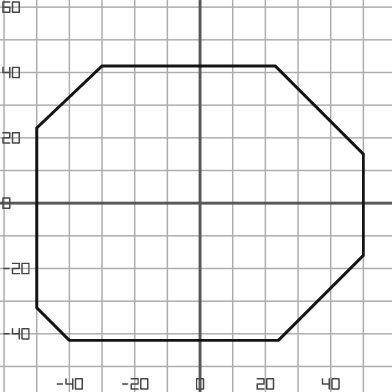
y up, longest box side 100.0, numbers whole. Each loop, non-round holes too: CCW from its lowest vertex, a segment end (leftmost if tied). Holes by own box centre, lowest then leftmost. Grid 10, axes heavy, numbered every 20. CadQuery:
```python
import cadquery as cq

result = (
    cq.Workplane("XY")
    .moveTo(-40.0, -42.0)
    .lineTo(24.0, -42.0)
    .lineTo(50.0, -16.0)
    .lineTo(50.0, 15.0)
    .lineTo(23.0, 42.0)
    .lineTo(-30.0, 42.0)
    .lineTo(-50.0, 23.0)
    .lineTo(-50.0, -32.0)
    .close()
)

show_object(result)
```